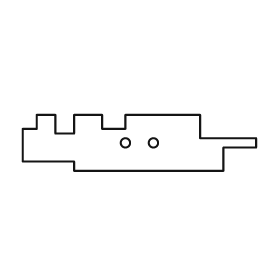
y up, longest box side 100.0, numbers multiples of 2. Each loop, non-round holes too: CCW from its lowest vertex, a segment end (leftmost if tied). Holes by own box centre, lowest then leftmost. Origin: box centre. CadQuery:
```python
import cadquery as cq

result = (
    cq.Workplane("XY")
    .moveTo(-28.0, -12.0)
    .lineTo(36.0, -12.0)
    .lineTo(36.0, -2.0)
    .lineTo(50.0, -2.0)
    .lineTo(50.0, 2.0)
    .lineTo(26.0, 2.0)
    .lineTo(26.0, 12.0)
    .lineTo(-6.0, 12.0)
    .lineTo(-6.0, 6.0)
    .lineTo(-16.0, 6.0)
    .lineTo(-16.0, 12.0)
    .lineTo(-28.0, 12.0)
    .lineTo(-28.0, 4.0)
    .lineTo(-36.0, 4.0)
    .lineTo(-36.0, 12.0)
    .lineTo(-44.0, 12.0)
    .lineTo(-44.0, 6.0)
    .lineTo(-50.0, 6.0)
    .lineTo(-50.0, -8.0)
    .lineTo(-28.0, -8.0)
    .close()
    .moveTo(-6.0, 0.0)
    .circle(2.0)
    .moveTo(6.0, 0.0)
    .circle(2.0)
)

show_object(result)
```